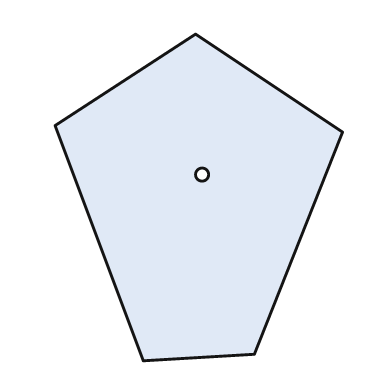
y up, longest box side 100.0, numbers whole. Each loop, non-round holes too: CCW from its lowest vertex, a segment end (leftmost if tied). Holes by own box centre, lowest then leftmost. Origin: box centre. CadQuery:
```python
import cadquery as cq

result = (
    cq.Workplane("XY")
    .moveTo(-17.0, -50.0)
    .lineTo(17.0, -48.0)
    .lineTo(44.0, 20.0)
    .lineTo(-1.0, 50.0)
    .lineTo(-44.0, 22.0)
    .close()
    .moveTo(1.0, 7.0)
    .circle(2.0)
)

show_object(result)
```